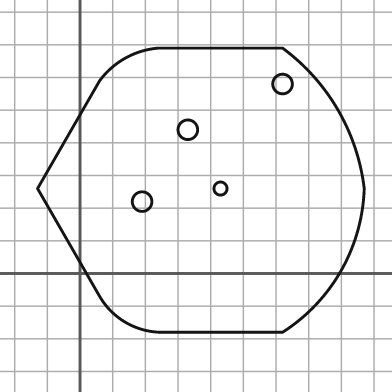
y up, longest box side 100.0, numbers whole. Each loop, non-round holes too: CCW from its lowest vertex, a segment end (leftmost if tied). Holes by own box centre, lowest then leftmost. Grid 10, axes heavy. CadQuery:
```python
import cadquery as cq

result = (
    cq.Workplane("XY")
    .moveTo(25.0, -18.0)
    .lineTo(62.0, -18.0)
    .threePointArc((80.0, 1.0), (87.0, 26.0))
    .threePointArc((79.0, 50.0), (62.0, 69.0))
    .lineTo(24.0, 69.0)
    .threePointArc((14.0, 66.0), (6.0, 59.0))
    .lineTo(-13.0, 26.0)
    .lineTo(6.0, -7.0)
    .threePointArc((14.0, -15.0), (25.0, -18.0))
    .close()
    .moveTo(19.0, 22.0)
    .circle(3.0)
    .moveTo(43.0, 26.0)
    .circle(2.0)
    .moveTo(33.0, 44.0)
    .circle(3.0)
    .moveTo(62.0, 58.0)
    .circle(3.0)
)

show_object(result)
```